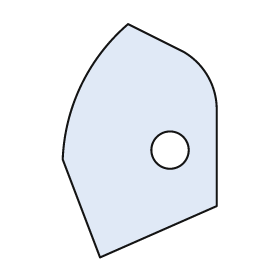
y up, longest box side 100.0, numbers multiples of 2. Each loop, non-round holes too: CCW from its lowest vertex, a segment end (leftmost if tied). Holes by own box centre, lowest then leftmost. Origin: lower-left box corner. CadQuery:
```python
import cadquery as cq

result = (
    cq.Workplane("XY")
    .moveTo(16.0, 0.0)
    .lineTo(66.0, 22.0)
    .lineTo(66.0, 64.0)
    .threePointArc((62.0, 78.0), (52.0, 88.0))
    .lineTo(28.0, 100.0)
    .threePointArc((8.0, 74.0), (0.0, 42.0))
    .close()
    .moveTo(46.0, 46.0)
    .circle(8.0)
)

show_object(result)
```